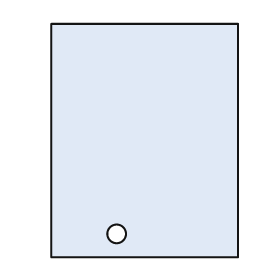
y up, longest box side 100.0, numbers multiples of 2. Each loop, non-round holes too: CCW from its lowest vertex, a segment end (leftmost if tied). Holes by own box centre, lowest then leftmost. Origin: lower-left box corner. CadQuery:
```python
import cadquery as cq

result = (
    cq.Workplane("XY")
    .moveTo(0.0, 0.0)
    .lineTo(80.0, 0.0)
    .lineTo(80.0, 100.0)
    .lineTo(0.0, 100.0)
    .close()
    .moveTo(28.0, 10.0)
    .circle(4.0)
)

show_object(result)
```